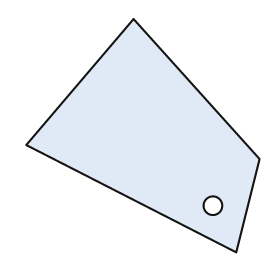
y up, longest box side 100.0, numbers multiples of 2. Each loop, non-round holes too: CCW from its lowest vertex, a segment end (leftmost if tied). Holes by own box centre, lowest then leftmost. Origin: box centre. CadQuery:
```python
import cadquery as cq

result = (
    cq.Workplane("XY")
    .moveTo(40.0, -50.0)
    .lineTo(50.0, -10.0)
    .lineTo(-4.0, 50.0)
    .lineTo(-50.0, -4.0)
    .close()
    .moveTo(30.0, -30.0)
    .circle(4.0)
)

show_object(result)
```